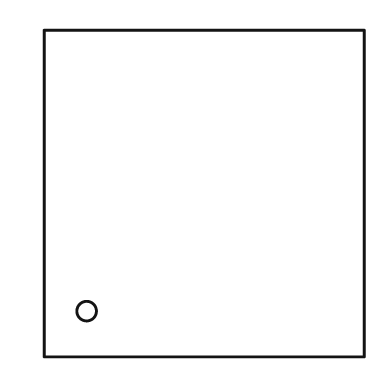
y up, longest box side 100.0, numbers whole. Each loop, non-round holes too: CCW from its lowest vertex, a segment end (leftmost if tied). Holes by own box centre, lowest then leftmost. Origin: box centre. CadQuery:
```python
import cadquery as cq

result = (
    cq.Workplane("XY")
    .moveTo(-49.0, -50.0)
    .lineTo(49.0, -50.0)
    .lineTo(49.0, 50.0)
    .lineTo(-49.0, 50.0)
    .close()
    .moveTo(-36.0, -36.0)
    .circle(3.0)
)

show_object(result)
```